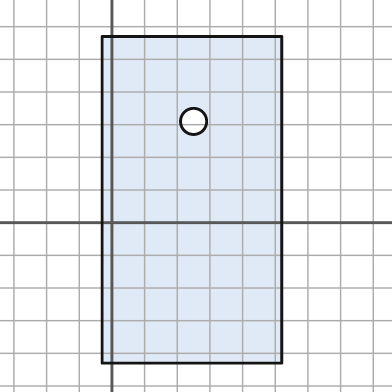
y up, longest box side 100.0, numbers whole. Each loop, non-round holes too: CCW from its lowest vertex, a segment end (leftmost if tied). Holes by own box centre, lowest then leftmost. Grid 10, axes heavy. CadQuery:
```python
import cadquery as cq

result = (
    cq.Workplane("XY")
    .moveTo(-3.0, -43.0)
    .lineTo(52.0, -43.0)
    .lineTo(52.0, 57.0)
    .lineTo(-3.0, 57.0)
    .close()
    .moveTo(25.0, 31.0)
    .circle(4.0)
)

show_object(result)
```